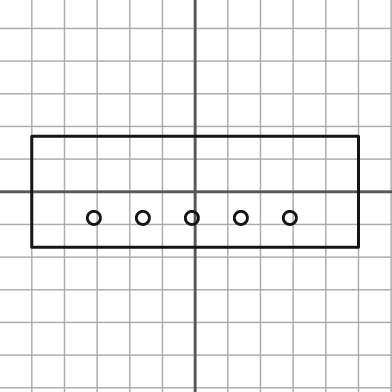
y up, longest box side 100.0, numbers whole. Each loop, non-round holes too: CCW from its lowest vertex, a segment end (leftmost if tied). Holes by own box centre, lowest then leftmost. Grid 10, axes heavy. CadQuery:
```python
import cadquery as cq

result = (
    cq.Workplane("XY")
    .moveTo(-50.0, -17.0)
    .lineTo(50.0, -17.0)
    .lineTo(50.0, 17.0)
    .lineTo(-50.0, 17.0)
    .close()
    .moveTo(-31.0, -8.0)
    .circle(2.0)
    .moveTo(-16.0, -8.0)
    .circle(2.0)
    .moveTo(-1.0, -8.0)
    .circle(2.0)
    .moveTo(14.0, -8.0)
    .circle(2.0)
    .moveTo(29.0, -8.0)
    .circle(2.0)
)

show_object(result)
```